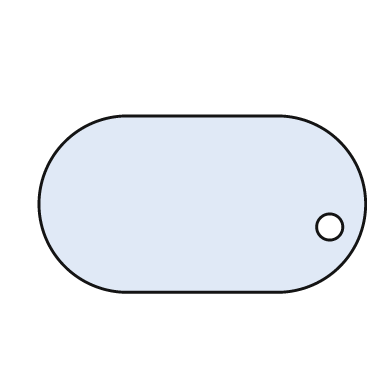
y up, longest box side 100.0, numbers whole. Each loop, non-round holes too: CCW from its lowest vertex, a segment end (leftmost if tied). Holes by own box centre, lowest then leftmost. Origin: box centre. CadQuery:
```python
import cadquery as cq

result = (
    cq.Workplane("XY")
    .moveTo(-23.0, -27.0)
    .lineTo(23.0, -27.0)
    .threePointArc((50.0, 0.0), (23.0, 27.0))
    .lineTo(-23.0, 27.0)
    .threePointArc((-50.0, 0.0), (-23.0, -27.0))
    .close()
    .moveTo(39.0, -7.0)
    .circle(4.0)
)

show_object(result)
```